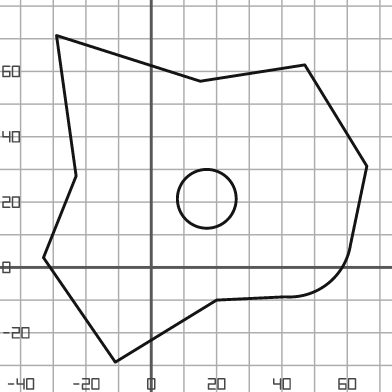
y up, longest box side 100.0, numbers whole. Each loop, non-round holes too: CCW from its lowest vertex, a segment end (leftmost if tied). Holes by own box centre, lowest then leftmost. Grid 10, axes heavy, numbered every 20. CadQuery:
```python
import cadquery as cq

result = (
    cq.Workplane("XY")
    .moveTo(-11.0, -29.0)
    .lineTo(20.0, -10.0)
    .lineTo(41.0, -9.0)
    .threePointArc((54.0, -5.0), (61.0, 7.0))
    .lineTo(66.0, 31.0)
    .lineTo(47.0, 62.0)
    .lineTo(15.0, 57.0)
    .lineTo(-29.0, 71.0)
    .lineTo(-23.0, 28.0)
    .lineTo(-33.0, 3.0)
    .close()
    .moveTo(17.0, 21.0)
    .circle(9.0)
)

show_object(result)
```